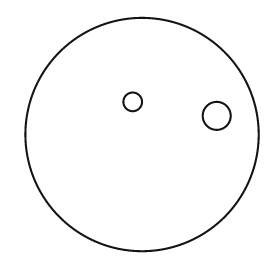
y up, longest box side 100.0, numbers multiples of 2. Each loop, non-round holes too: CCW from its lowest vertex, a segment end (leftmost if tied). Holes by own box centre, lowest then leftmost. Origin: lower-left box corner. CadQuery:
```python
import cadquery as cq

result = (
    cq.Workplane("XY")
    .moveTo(50.0, 50.0)
    .circle(50.0)
    .moveTo(82.0, 58.0)
    .circle(6.0)
    .moveTo(46.0, 64.0)
    .circle(4.0)
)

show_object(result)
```